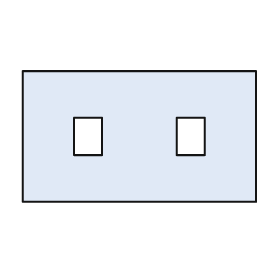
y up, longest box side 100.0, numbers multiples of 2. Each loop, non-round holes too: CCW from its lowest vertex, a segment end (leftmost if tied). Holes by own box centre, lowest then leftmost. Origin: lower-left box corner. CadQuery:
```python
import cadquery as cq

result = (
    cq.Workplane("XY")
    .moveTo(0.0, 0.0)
    .lineTo(100.0, 0.0)
    .lineTo(100.0, 56.0)
    .lineTo(0.0, 56.0)
    .close()
    .moveTo(22.0, 20.0)
    .lineTo(34.0, 20.0)
    .lineTo(34.0, 36.0)
    .lineTo(22.0, 36.0)
    .close()
    .moveTo(66.0, 20.0)
    .lineTo(78.0, 20.0)
    .lineTo(78.0, 36.0)
    .lineTo(66.0, 36.0)
    .close()
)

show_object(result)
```